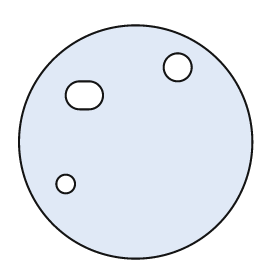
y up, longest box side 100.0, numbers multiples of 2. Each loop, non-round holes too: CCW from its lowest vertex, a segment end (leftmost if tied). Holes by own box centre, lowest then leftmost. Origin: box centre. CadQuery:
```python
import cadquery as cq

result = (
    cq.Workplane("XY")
    .moveTo(0.0, 0.0)
    .circle(50.0)
    .moveTo(-30.0, -18.0)
    .circle(4.0)
    .moveTo(-24.0, 14.0)
    .lineTo(-20.0, 14.0)
    .threePointArc((-14.0, 20.0), (-20.0, 26.0))
    .lineTo(-24.0, 26.0)
    .threePointArc((-30.0, 20.0), (-24.0, 14.0))
    .close()
    .moveTo(18.0, 32.0)
    .circle(6.0)
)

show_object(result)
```